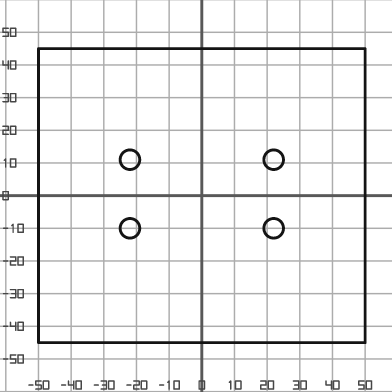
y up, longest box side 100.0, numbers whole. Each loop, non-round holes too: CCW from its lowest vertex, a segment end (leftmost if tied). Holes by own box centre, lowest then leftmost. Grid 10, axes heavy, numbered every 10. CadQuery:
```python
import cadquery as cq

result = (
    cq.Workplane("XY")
    .moveTo(-50.0, -45.0)
    .lineTo(50.0, -45.0)
    .lineTo(50.0, 45.0)
    .lineTo(-50.0, 45.0)
    .close()
    .moveTo(-22.0, -10.0)
    .circle(3.0)
    .moveTo(22.0, -10.0)
    .circle(3.0)
    .moveTo(-22.0, 11.0)
    .circle(3.0)
    .moveTo(22.0, 11.0)
    .circle(3.0)
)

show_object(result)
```